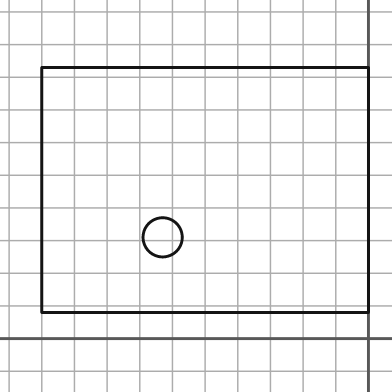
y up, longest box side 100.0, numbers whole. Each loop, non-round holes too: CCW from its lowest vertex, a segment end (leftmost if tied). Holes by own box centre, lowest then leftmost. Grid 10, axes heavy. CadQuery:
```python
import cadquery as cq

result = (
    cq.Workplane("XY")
    .moveTo(-100.0, 8.0)
    .lineTo(0.0, 8.0)
    .lineTo(0.0, 83.0)
    .lineTo(-100.0, 83.0)
    .close()
    .moveTo(-63.0, 31.0)
    .circle(6.0)
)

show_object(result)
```